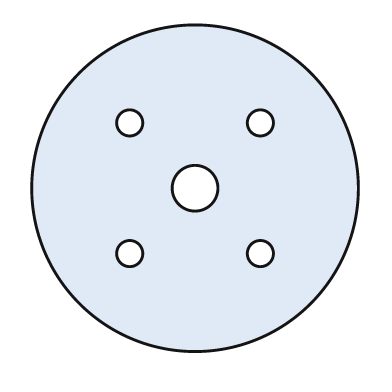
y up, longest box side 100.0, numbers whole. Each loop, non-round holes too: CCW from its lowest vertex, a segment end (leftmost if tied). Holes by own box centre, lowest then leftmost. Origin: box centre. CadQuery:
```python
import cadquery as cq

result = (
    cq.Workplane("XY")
    .moveTo(0.0, 0.0)
    .circle(50.0)
    .moveTo(-20.0, -20.0)
    .circle(4.0)
    .moveTo(20.0, -20.0)
    .circle(4.0)
    .moveTo(0.0, 0.0)
    .circle(7.0)
    .moveTo(-20.0, 20.0)
    .circle(4.0)
    .moveTo(20.0, 20.0)
    .circle(4.0)
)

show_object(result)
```